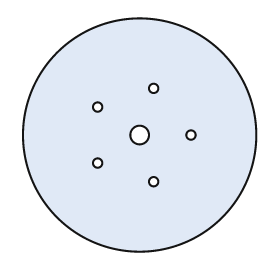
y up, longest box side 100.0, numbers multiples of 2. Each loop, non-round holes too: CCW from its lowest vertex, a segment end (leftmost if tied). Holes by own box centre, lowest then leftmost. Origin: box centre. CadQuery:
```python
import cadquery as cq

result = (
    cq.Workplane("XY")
    .moveTo(0.0, 0.0)
    .circle(50.0)
    .moveTo(6.0, -20.0)
    .circle(2.0)
    .moveTo(-18.0, -12.0)
    .circle(2.0)
    .moveTo(0.0, 0.0)
    .circle(4.0)
    .moveTo(22.0, 0.0)
    .circle(2.0)
    .moveTo(-18.0, 12.0)
    .circle(2.0)
    .moveTo(6.0, 20.0)
    .circle(2.0)
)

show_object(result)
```